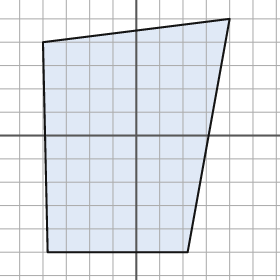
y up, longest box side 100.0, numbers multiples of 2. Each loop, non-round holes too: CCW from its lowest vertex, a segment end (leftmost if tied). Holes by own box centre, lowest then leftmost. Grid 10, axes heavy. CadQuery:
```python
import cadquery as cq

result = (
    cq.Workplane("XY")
    .moveTo(-38.0, -50.0)
    .lineTo(22.0, -50.0)
    .lineTo(40.0, 50.0)
    .lineTo(-40.0, 40.0)
    .close()
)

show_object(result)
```